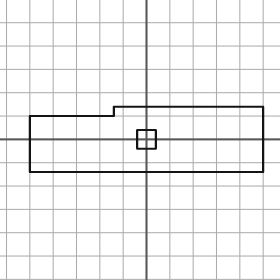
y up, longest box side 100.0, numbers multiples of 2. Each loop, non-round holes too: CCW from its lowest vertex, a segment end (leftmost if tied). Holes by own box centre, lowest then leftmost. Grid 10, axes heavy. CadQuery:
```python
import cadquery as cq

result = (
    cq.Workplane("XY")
    .moveTo(-50.0, -14.0)
    .lineTo(50.0, -14.0)
    .lineTo(50.0, 14.0)
    .lineTo(-14.0, 14.0)
    .lineTo(-14.0, 10.0)
    .lineTo(-50.0, 10.0)
    .close()
    .moveTo(-4.0, -4.0)
    .lineTo(4.0, -4.0)
    .lineTo(4.0, 4.0)
    .lineTo(-4.0, 4.0)
    .close()
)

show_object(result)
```